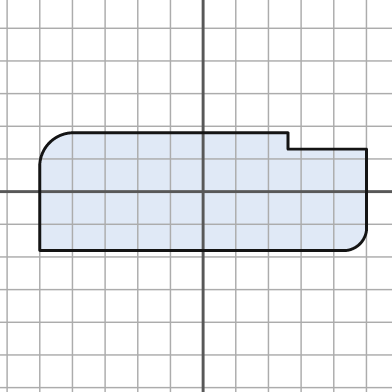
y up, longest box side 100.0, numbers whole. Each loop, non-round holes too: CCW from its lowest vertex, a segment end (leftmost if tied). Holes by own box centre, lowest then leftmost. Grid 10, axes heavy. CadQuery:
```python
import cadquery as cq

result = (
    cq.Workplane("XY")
    .moveTo(-50.0, -18.0)
    .lineTo(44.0, -18.0)
    .threePointArc((48.0, -16.0), (50.0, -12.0))
    .lineTo(50.0, 13.0)
    .lineTo(26.0, 13.0)
    .lineTo(26.0, 18.0)
    .lineTo(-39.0, 18.0)
    .threePointArc((-47.0, 15.0), (-50.0, 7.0))
    .close()
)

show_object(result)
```